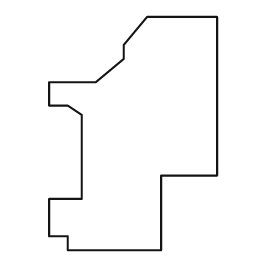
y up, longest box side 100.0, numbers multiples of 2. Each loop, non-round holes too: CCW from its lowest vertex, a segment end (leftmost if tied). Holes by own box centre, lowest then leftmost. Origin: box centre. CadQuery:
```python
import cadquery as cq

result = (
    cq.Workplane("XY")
    .moveTo(-28.0, -50.0)
    .lineTo(12.0, -50.0)
    .lineTo(12.0, -18.0)
    .lineTo(36.0, -18.0)
    .lineTo(36.0, 50.0)
    .lineTo(6.0, 50.0)
    .lineTo(-4.0, 38.0)
    .lineTo(-4.0, 32.0)
    .lineTo(-16.0, 22.0)
    .lineTo(-36.0, 22.0)
    .lineTo(-36.0, 12.0)
    .lineTo(-28.0, 12.0)
    .lineTo(-22.0, 8.0)
    .lineTo(-22.0, -28.0)
    .lineTo(-36.0, -28.0)
    .lineTo(-36.0, -44.0)
    .lineTo(-28.0, -44.0)
    .close()
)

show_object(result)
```